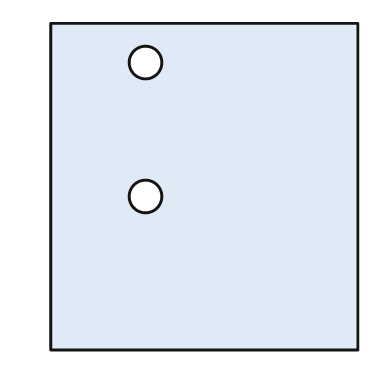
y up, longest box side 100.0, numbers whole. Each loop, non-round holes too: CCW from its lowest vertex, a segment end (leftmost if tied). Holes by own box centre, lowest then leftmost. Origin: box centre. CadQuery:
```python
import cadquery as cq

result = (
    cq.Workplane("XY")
    .moveTo(-47.0, -50.0)
    .lineTo(47.0, -50.0)
    .lineTo(47.0, 50.0)
    .lineTo(-47.0, 50.0)
    .close()
    .moveTo(-18.0, -3.0)
    .circle(5.0)
    .moveTo(-18.0, 38.0)
    .circle(5.0)
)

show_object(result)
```